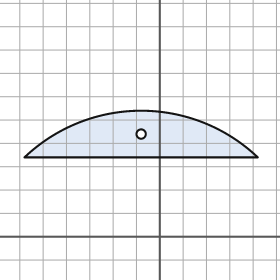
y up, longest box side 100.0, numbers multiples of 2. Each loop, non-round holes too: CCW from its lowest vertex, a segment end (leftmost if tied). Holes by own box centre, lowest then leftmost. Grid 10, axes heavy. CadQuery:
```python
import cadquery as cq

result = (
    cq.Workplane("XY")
    .moveTo(-58.0, 34.0)
    .lineTo(42.0, 34.0)
    .threePointArc((-8.0, 54.0), (-58.0, 34.0))
    .close()
    .moveTo(-8.0, 44.0)
    .circle(2.0)
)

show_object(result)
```